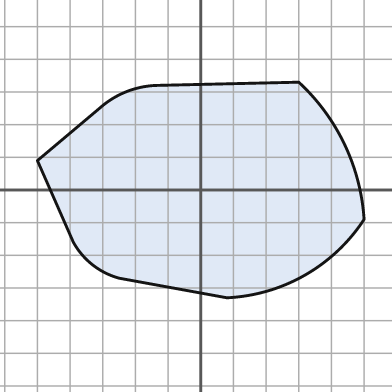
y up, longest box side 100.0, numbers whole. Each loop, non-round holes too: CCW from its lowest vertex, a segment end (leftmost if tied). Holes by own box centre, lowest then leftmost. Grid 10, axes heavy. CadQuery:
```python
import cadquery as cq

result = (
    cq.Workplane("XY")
    .moveTo(8.0, -33.0)
    .threePointArc((32.0, -26.0), (50.0, -9.0))
    .threePointArc((44.0, 14.0), (30.0, 33.0))
    .lineTo(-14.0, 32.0)
    .threePointArc((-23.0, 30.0), (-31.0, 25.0))
    .lineTo(-50.0, 9.0)
    .lineTo(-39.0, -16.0)
    .threePointArc((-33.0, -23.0), (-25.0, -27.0))
    .close()
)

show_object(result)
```